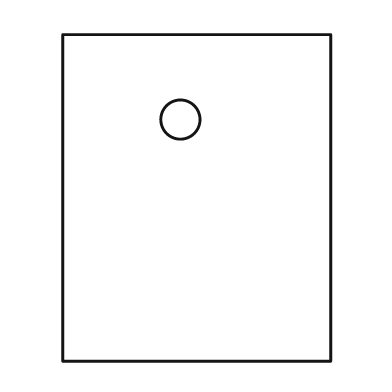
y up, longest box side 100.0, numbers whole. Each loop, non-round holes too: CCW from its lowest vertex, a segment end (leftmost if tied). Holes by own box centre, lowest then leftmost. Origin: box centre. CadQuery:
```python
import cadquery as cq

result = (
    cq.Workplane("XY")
    .moveTo(-41.0, -50.0)
    .lineTo(41.0, -50.0)
    .lineTo(41.0, 50.0)
    .lineTo(-41.0, 50.0)
    .close()
    .moveTo(-5.0, 24.0)
    .circle(6.0)
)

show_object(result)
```